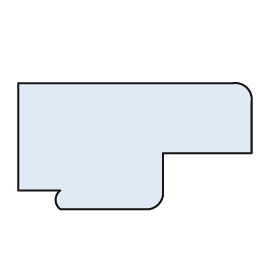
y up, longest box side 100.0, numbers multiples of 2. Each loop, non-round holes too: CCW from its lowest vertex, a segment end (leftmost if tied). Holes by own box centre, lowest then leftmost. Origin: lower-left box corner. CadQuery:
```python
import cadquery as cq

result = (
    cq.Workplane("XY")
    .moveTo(18.0, 0.0)
    .lineTo(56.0, 0.0)
    .threePointArc((60.0, 2.0), (62.0, 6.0))
    .lineTo(62.0, 24.0)
    .lineTo(100.0, 24.0)
    .lineTo(100.0, 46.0)
    .threePointArc((98.0, 52.0), (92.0, 54.0))
    .lineTo(0.0, 54.0)
    .lineTo(0.0, 8.0)
    .lineTo(18.0, 8.0)
    .threePointArc((16.0, 4.0), (18.0, 0.0))
    .close()
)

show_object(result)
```